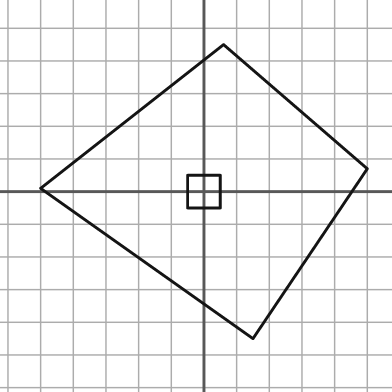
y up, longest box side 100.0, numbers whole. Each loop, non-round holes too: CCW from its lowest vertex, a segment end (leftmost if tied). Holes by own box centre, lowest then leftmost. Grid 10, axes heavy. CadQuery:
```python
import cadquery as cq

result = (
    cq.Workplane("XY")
    .moveTo(15.0, -45.0)
    .lineTo(50.0, 7.0)
    .lineTo(6.0, 45.0)
    .lineTo(-50.0, 1.0)
    .close()
    .moveTo(-5.0, -5.0)
    .lineTo(5.0, -5.0)
    .lineTo(5.0, 5.0)
    .lineTo(-5.0, 5.0)
    .close()
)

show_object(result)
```